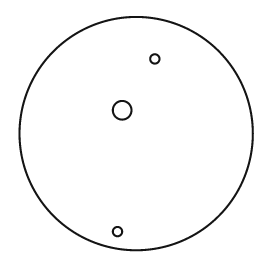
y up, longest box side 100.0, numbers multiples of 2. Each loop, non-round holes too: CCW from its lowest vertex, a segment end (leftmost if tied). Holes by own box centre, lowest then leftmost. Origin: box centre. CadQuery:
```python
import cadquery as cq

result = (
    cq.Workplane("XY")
    .moveTo(0.0, 0.0)
    .circle(50.0)
    .moveTo(-8.0, -42.0)
    .circle(2.0)
    .moveTo(-6.0, 10.0)
    .circle(4.0)
    .moveTo(8.0, 32.0)
    .circle(2.0)
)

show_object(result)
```